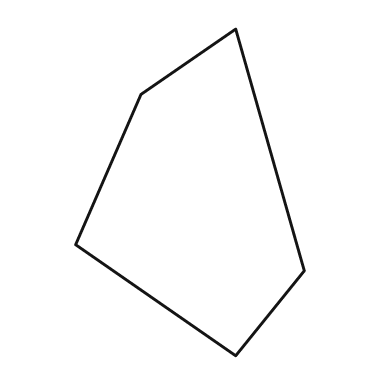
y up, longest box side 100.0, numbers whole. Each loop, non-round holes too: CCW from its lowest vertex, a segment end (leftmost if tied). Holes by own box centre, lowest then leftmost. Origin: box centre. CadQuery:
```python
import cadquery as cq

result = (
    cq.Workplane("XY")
    .moveTo(14.0, -50.0)
    .lineTo(35.0, -24.0)
    .lineTo(14.0, 50.0)
    .lineTo(-15.0, 30.0)
    .lineTo(-35.0, -16.0)
    .close()
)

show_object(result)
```